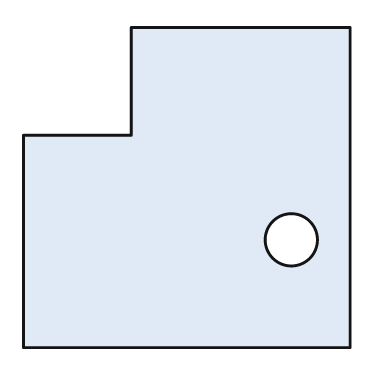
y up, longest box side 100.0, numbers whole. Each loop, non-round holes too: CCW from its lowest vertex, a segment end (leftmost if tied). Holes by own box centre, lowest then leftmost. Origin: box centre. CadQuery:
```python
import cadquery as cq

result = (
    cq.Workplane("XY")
    .moveTo(-50.0, -49.0)
    .lineTo(50.0, -49.0)
    .lineTo(50.0, 49.0)
    .lineTo(-17.0, 49.0)
    .lineTo(-17.0, 16.0)
    .lineTo(-50.0, 16.0)
    .close()
    .moveTo(32.0, -16.0)
    .circle(8.0)
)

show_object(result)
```